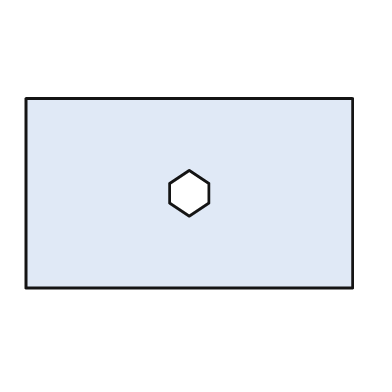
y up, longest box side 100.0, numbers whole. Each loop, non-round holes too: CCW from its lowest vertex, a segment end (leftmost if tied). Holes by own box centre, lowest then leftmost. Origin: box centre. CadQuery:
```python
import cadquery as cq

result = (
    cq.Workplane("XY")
    .moveTo(-50.0, -29.0)
    .lineTo(50.0, -29.0)
    .lineTo(50.0, 29.0)
    .lineTo(-50.0, 29.0)
    .close()
    .moveTo(0.0, -7.0)
    .lineTo(6.0, -3.0)
    .lineTo(6.0, 3.0)
    .lineTo(0.0, 7.0)
    .lineTo(-6.0, 3.0)
    .lineTo(-6.0, -3.0)
    .close()
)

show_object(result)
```